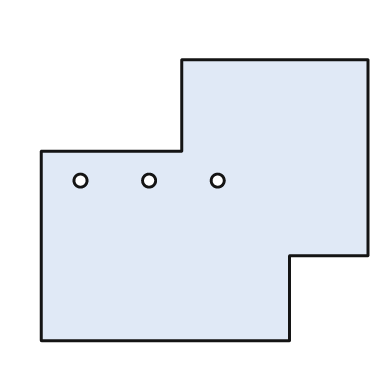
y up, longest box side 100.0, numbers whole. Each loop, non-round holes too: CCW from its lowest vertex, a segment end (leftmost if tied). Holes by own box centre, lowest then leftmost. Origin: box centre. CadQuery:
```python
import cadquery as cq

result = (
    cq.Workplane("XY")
    .moveTo(-50.0, -43.0)
    .lineTo(26.0, -43.0)
    .lineTo(26.0, -17.0)
    .lineTo(50.0, -17.0)
    .lineTo(50.0, 43.0)
    .lineTo(-7.0, 43.0)
    .lineTo(-7.0, 15.0)
    .lineTo(-50.0, 15.0)
    .close()
    .moveTo(-38.0, 6.0)
    .circle(2.0)
    .moveTo(-17.0, 6.0)
    .circle(2.0)
    .moveTo(4.0, 6.0)
    .circle(2.0)
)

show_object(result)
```